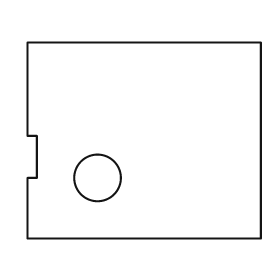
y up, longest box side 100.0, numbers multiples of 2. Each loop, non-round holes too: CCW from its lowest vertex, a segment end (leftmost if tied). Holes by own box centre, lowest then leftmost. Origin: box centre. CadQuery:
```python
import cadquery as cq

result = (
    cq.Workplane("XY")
    .moveTo(-50.0, -42.0)
    .lineTo(50.0, -42.0)
    .lineTo(50.0, 42.0)
    .lineTo(-50.0, 42.0)
    .lineTo(-50.0, 2.0)
    .lineTo(-46.0, 2.0)
    .lineTo(-46.0, -16.0)
    .lineTo(-50.0, -16.0)
    .close()
    .moveTo(-20.0, -16.0)
    .circle(10.0)
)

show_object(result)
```